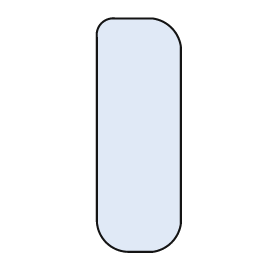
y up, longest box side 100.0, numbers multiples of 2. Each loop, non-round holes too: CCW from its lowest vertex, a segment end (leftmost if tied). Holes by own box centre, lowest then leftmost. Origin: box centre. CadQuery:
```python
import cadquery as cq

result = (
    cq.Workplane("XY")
    .moveTo(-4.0, -50.0)
    .lineTo(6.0, -50.0)
    .threePointArc((14.0, -46.0), (18.0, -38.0))
    .lineTo(18.0, 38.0)
    .threePointArc((14.0, 46.0), (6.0, 50.0))
    .lineTo(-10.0, 50.0)
    .threePointArc((-16.0, 48.0), (-18.0, 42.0))
    .lineTo(-18.0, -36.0)
    .threePointArc((-14.0, -46.0), (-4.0, -50.0))
    .close()
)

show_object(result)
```